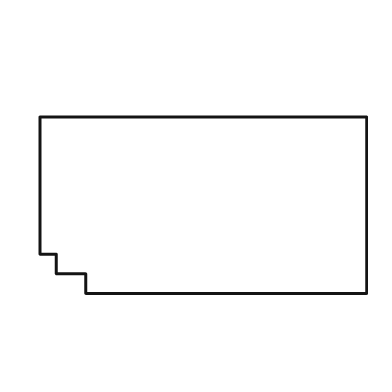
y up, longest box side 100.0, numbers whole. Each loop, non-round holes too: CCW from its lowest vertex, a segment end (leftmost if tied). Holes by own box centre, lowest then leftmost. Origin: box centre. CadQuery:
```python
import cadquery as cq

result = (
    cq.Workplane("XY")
    .moveTo(-36.0, -27.0)
    .lineTo(50.0, -27.0)
    .lineTo(50.0, 27.0)
    .lineTo(-50.0, 27.0)
    .lineTo(-50.0, -15.0)
    .lineTo(-45.0, -15.0)
    .lineTo(-45.0, -21.0)
    .lineTo(-36.0, -21.0)
    .close()
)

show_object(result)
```